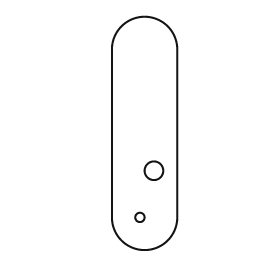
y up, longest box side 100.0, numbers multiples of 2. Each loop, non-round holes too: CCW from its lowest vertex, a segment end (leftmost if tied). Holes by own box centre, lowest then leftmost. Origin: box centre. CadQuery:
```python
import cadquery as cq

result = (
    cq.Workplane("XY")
    .moveTo(-14.0, -36.0)
    .threePointArc((0.0, -50.0), (14.0, -36.0))
    .lineTo(14.0, 36.0)
    .threePointArc((0.0, 50.0), (-14.0, 36.0))
    .close()
    .moveTo(-2.0, -36.0)
    .circle(2.0)
    .moveTo(4.0, -16.0)
    .circle(4.0)
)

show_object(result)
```